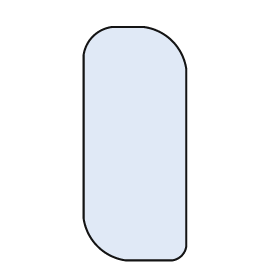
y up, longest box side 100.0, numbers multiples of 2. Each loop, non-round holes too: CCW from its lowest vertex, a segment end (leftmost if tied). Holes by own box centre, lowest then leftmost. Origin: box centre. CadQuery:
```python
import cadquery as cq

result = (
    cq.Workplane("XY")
    .moveTo(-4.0, -50.0)
    .lineTo(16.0, -50.0)
    .threePointArc((20.0, -48.0), (22.0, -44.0))
    .lineTo(22.0, 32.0)
    .threePointArc((16.0, 44.0), (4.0, 50.0))
    .lineTo(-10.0, 50.0)
    .threePointArc((-18.0, 46.0), (-22.0, 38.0))
    .lineTo(-22.0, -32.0)
    .threePointArc((-16.0, -44.0), (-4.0, -50.0))
    .close()
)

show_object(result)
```